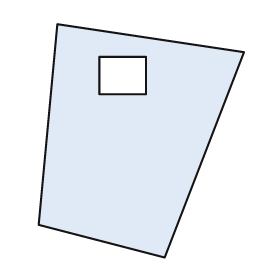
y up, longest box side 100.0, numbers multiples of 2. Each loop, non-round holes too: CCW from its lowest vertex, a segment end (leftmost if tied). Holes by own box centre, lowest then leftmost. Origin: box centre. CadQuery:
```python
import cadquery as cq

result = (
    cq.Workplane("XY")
    .moveTo(10.0, -50.0)
    .lineTo(44.0, 38.0)
    .lineTo(-36.0, 50.0)
    .lineTo(-44.0, -36.0)
    .close()
    .moveTo(-18.0, 20.0)
    .lineTo(2.0, 20.0)
    .lineTo(2.0, 36.0)
    .lineTo(-18.0, 36.0)
    .close()
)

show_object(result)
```